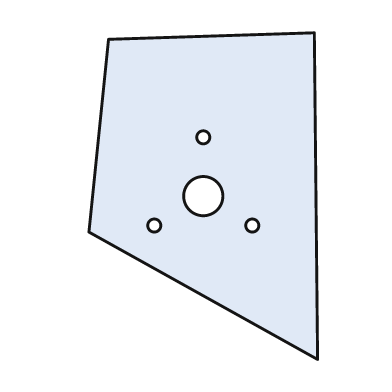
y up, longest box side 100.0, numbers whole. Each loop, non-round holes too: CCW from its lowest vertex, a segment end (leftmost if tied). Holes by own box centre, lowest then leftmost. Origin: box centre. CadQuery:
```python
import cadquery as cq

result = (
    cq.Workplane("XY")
    .moveTo(35.0, -50.0)
    .lineTo(34.0, 50.0)
    .lineTo(-29.0, 48.0)
    .lineTo(-35.0, -11.0)
    .close()
    .moveTo(-15.0, -9.0)
    .circle(2.0)
    .moveTo(15.0, -9.0)
    .circle(2.0)
    .moveTo(0.0, 0.0)
    .circle(6.0)
    .moveTo(0.0, 18.0)
    .circle(2.0)
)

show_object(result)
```